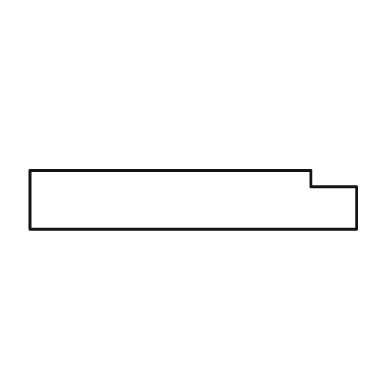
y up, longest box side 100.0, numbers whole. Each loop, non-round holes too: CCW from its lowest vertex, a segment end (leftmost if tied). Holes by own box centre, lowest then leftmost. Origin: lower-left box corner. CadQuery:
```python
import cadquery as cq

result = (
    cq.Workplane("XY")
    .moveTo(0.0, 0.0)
    .lineTo(100.0, 0.0)
    .lineTo(100.0, 13.0)
    .lineTo(86.0, 13.0)
    .lineTo(86.0, 18.0)
    .lineTo(0.0, 18.0)
    .close()
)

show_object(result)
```